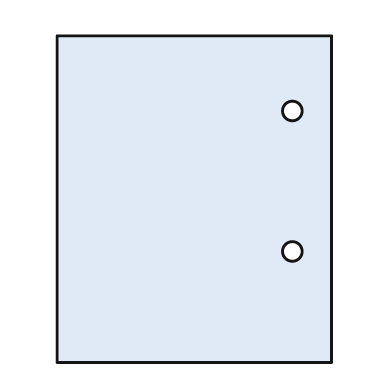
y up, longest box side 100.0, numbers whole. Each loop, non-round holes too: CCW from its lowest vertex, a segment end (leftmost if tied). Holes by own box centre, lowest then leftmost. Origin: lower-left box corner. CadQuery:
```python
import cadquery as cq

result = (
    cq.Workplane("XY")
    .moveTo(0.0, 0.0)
    .lineTo(84.0, 0.0)
    .lineTo(84.0, 100.0)
    .lineTo(0.0, 100.0)
    .close()
    .moveTo(72.0, 34.0)
    .circle(3.0)
    .moveTo(72.0, 77.0)
    .circle(3.0)
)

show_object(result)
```